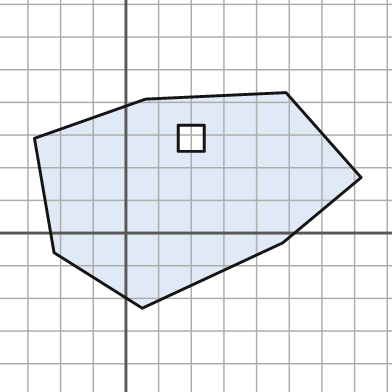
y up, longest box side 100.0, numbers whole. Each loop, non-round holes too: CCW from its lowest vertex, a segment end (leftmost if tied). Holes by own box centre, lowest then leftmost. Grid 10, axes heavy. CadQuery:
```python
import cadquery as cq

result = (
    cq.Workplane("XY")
    .moveTo(5.0, -23.0)
    .lineTo(48.0, -3.0)
    .lineTo(72.0, 17.0)
    .lineTo(49.0, 43.0)
    .lineTo(6.0, 41.0)
    .lineTo(-28.0, 29.0)
    .lineTo(-22.0, -6.0)
    .close()
    .moveTo(16.0, 25.0)
    .lineTo(24.0, 25.0)
    .lineTo(24.0, 33.0)
    .lineTo(16.0, 33.0)
    .close()
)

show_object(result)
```